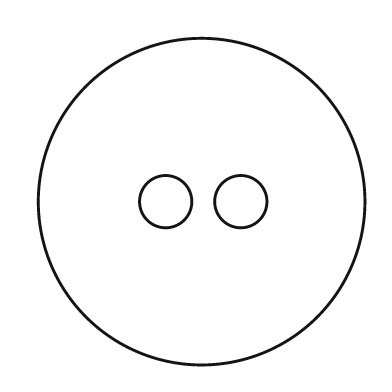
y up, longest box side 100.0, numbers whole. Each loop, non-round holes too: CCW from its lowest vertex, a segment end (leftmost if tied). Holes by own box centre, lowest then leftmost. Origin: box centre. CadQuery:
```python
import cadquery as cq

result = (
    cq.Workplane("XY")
    .moveTo(0.0, 0.0)
    .circle(50.0)
    .moveTo(-11.0, 0.0)
    .circle(8.0)
    .moveTo(12.0, 0.0)
    .circle(8.0)
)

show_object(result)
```